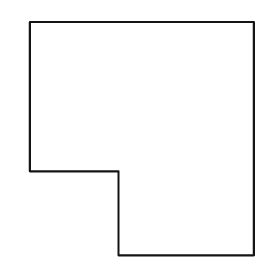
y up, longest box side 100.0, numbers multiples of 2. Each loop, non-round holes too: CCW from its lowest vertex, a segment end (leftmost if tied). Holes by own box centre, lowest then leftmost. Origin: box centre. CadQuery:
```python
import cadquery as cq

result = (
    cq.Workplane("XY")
    .moveTo(-10.0, -50.0)
    .lineTo(48.0, -50.0)
    .lineTo(48.0, 50.0)
    .lineTo(-48.0, 50.0)
    .lineTo(-48.0, -14.0)
    .lineTo(-10.0, -14.0)
    .close()
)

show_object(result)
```